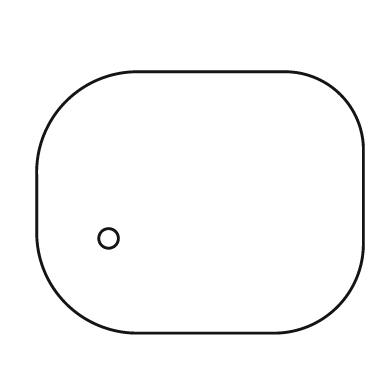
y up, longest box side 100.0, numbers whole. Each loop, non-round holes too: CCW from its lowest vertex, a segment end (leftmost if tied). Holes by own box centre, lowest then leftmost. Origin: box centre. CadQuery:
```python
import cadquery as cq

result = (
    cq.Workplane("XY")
    .moveTo(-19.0, -40.0)
    .lineTo(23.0, -40.0)
    .threePointArc((42.0, -32.0), (50.0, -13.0))
    .lineTo(50.0, 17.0)
    .threePointArc((43.0, 33.0), (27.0, 40.0))
    .lineTo(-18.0, 40.0)
    .threePointArc((-41.0, 31.0), (-50.0, 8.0))
    .lineTo(-50.0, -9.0)
    .threePointArc((-41.0, -31.0), (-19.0, -40.0))
    .close()
    .moveTo(-28.0, -11.0)
    .circle(3.0)
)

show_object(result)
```